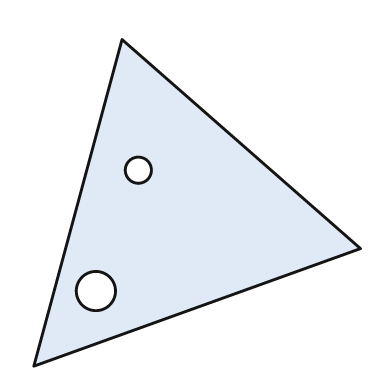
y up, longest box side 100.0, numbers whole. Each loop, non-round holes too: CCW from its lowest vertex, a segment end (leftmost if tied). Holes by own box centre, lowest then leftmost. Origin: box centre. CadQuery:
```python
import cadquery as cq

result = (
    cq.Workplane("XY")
    .moveTo(-50.0, -50.0)
    .lineTo(50.0, -14.0)
    .lineTo(-23.0, 50.0)
    .close()
    .moveTo(-31.0, -27.0)
    .circle(6.0)
    .moveTo(-18.0, 10.0)
    .circle(4.0)
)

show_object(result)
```